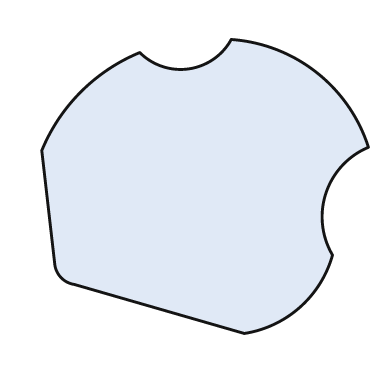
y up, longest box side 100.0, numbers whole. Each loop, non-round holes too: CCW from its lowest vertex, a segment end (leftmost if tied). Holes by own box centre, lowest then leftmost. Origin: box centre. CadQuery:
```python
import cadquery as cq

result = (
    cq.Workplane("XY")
    .moveTo(12.0, -45.0)
    .threePointArc((29.0, -37.0), (39.0, -21.0))
    .threePointArc((37.0, -2.0), (50.0, 12.0))
    .threePointArc((34.0, 35.0), (8.0, 45.0))
    .threePointArc((-5.0, 36.0), (-20.0, 41.0))
    .threePointArc((-38.0, 29.0), (-50.0, 11.0))
    .lineTo(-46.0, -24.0)
    .threePointArc((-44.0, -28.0), (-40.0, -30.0))
    .close()
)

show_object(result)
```